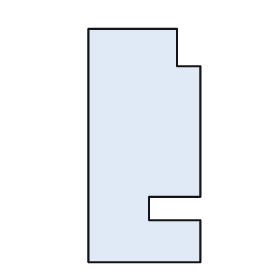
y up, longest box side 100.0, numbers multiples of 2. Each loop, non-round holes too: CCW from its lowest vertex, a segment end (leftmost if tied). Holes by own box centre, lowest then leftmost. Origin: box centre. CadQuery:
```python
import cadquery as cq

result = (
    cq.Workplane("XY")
    .moveTo(-24.0, -50.0)
    .lineTo(24.0, -50.0)
    .lineTo(24.0, -32.0)
    .lineTo(2.0, -32.0)
    .lineTo(2.0, -22.0)
    .lineTo(24.0, -22.0)
    .lineTo(24.0, 34.0)
    .lineTo(14.0, 34.0)
    .lineTo(14.0, 50.0)
    .lineTo(-24.0, 50.0)
    .close()
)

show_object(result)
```